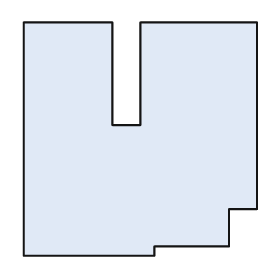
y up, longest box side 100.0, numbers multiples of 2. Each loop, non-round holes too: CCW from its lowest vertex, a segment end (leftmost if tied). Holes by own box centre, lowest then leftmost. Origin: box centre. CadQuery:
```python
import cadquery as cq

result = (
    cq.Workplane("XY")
    .moveTo(-50.0, -50.0)
    .lineTo(6.0, -50.0)
    .lineTo(6.0, -46.0)
    .lineTo(38.0, -46.0)
    .lineTo(38.0, -30.0)
    .lineTo(50.0, -30.0)
    .lineTo(50.0, 50.0)
    .lineTo(0.0, 50.0)
    .lineTo(0.0, 6.0)
    .lineTo(-12.0, 6.0)
    .lineTo(-12.0, 50.0)
    .lineTo(-50.0, 50.0)
    .close()
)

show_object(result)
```